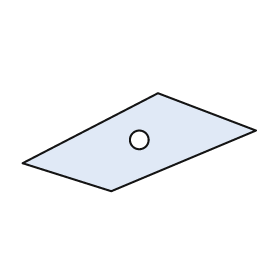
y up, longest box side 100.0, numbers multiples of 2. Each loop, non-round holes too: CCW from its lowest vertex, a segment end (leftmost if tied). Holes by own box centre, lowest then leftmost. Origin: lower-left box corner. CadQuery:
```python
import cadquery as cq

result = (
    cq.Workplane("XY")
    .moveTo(38.0, 0.0)
    .lineTo(100.0, 26.0)
    .lineTo(58.0, 42.0)
    .lineTo(0.0, 12.0)
    .close()
    .moveTo(50.0, 22.0)
    .circle(4.0)
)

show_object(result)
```